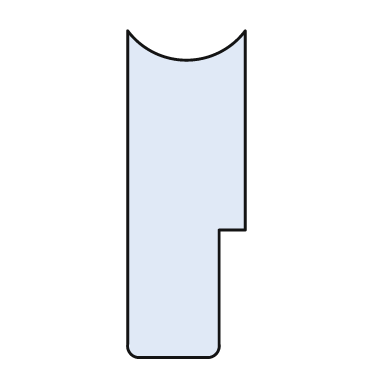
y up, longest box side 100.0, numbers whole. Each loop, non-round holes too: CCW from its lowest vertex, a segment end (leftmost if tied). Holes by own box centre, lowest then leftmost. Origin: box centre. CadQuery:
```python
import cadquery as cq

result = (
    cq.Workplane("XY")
    .moveTo(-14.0, -50.0)
    .lineTo(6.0, -50.0)
    .threePointArc((9.0, -49.0), (10.0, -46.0))
    .lineTo(10.0, -11.0)
    .lineTo(18.0, -11.0)
    .lineTo(18.0, 50.0)
    .threePointArc((0.0, 41.0), (-18.0, 50.0))
    .lineTo(-18.0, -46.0)
    .threePointArc((-17.0, -49.0), (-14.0, -50.0))
    .close()
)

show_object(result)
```